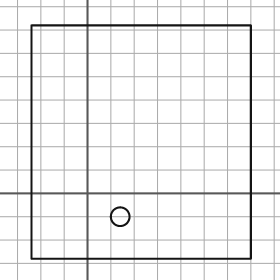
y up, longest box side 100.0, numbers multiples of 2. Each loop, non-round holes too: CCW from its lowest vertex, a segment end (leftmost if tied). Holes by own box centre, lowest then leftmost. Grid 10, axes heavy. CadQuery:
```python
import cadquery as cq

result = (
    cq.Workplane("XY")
    .moveTo(-24.0, -28.0)
    .lineTo(70.0, -28.0)
    .lineTo(70.0, 72.0)
    .lineTo(-24.0, 72.0)
    .close()
    .moveTo(14.0, -10.0)
    .circle(4.0)
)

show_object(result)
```